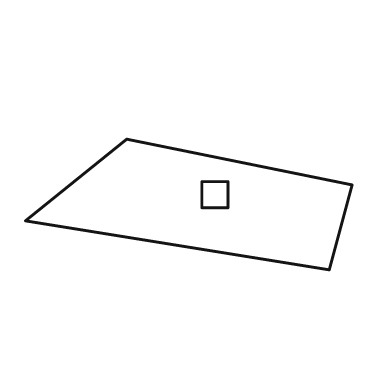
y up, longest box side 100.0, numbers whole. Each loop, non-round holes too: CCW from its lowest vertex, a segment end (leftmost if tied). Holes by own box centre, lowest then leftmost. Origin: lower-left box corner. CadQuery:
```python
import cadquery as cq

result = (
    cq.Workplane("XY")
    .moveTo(93.0, 0.0)
    .lineTo(100.0, 26.0)
    .lineTo(31.0, 40.0)
    .lineTo(0.0, 15.0)
    .close()
    .moveTo(54.0, 19.0)
    .lineTo(62.0, 19.0)
    .lineTo(62.0, 27.0)
    .lineTo(54.0, 27.0)
    .close()
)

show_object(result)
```